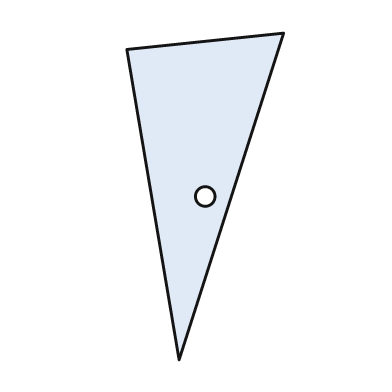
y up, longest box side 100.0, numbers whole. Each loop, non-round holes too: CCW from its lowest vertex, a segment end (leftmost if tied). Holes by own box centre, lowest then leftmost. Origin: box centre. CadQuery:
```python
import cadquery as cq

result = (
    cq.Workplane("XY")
    .moveTo(-8.0, -50.0)
    .lineTo(24.0, 50.0)
    .lineTo(-24.0, 45.0)
    .close()
    .moveTo(0.0, 0.0)
    .circle(3.0)
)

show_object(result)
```